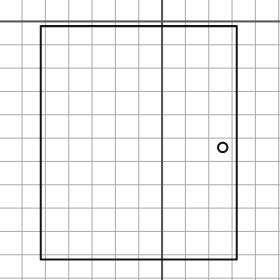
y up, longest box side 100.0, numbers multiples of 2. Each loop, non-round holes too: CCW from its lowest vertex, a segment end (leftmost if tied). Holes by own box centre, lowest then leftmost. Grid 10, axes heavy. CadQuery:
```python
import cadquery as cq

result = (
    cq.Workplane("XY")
    .moveTo(-52.0, -102.0)
    .lineTo(32.0, -102.0)
    .lineTo(32.0, -2.0)
    .lineTo(-52.0, -2.0)
    .close()
    .moveTo(26.0, -54.0)
    .circle(2.0)
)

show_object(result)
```